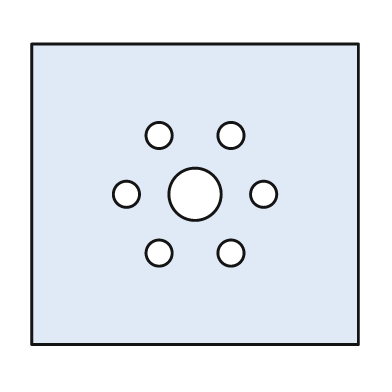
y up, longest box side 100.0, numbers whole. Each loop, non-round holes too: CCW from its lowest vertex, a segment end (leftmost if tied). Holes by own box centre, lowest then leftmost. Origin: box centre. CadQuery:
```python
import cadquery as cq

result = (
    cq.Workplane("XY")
    .moveTo(-50.0, -46.0)
    .lineTo(50.0, -46.0)
    .lineTo(50.0, 46.0)
    .lineTo(-50.0, 46.0)
    .close()
    .moveTo(-11.0, -18.0)
    .circle(4.0)
    .moveTo(11.0, -18.0)
    .circle(4.0)
    .moveTo(-21.0, 0.0)
    .circle(4.0)
    .moveTo(0.0, 0.0)
    .circle(8.0)
    .moveTo(21.0, 0.0)
    .circle(4.0)
    .moveTo(-11.0, 18.0)
    .circle(4.0)
    .moveTo(11.0, 18.0)
    .circle(4.0)
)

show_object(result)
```